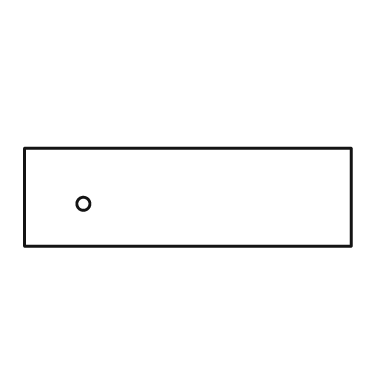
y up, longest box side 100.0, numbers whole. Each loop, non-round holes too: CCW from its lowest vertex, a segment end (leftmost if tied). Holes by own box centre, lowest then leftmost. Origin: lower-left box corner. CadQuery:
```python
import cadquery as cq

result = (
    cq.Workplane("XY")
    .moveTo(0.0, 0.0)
    .lineTo(100.0, 0.0)
    .lineTo(100.0, 30.0)
    .lineTo(0.0, 30.0)
    .close()
    .moveTo(18.0, 13.0)
    .circle(2.0)
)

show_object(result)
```